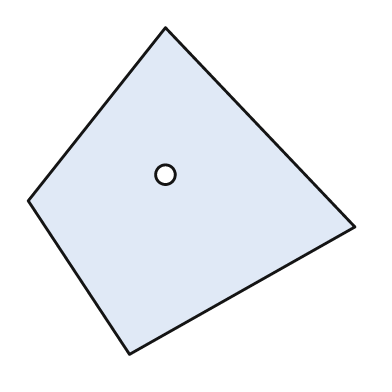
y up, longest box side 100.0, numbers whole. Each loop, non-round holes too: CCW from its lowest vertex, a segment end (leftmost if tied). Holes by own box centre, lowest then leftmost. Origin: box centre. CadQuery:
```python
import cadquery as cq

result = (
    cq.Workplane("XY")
    .moveTo(-19.0, -50.0)
    .lineTo(50.0, -11.0)
    .lineTo(-8.0, 50.0)
    .lineTo(-50.0, -3.0)
    .close()
    .moveTo(-8.0, 5.0)
    .circle(3.0)
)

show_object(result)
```